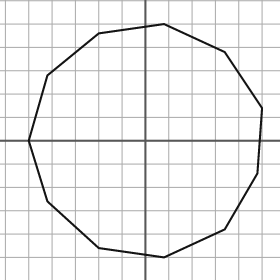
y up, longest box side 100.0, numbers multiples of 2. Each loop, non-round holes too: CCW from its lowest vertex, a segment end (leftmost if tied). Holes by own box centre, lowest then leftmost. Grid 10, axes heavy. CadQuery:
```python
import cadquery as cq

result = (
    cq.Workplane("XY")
    .moveTo(8.0, -50.0)
    .lineTo(34.0, -38.0)
    .lineTo(48.0, -14.0)
    .lineTo(50.0, 14.0)
    .lineTo(34.0, 38.0)
    .lineTo(8.0, 50.0)
    .lineTo(-20.0, 46.0)
    .lineTo(-42.0, 28.0)
    .lineTo(-50.0, 0.0)
    .lineTo(-42.0, -26.0)
    .lineTo(-20.0, -46.0)
    .close()
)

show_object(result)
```